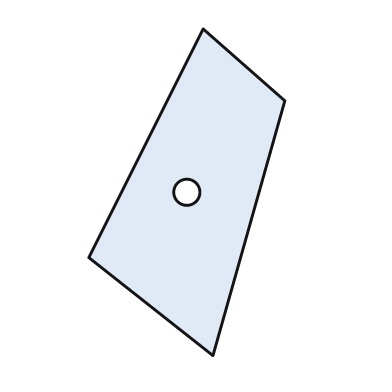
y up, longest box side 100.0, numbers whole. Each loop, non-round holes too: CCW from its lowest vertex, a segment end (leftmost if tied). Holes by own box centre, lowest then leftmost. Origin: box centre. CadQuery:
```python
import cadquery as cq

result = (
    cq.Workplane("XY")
    .moveTo(8.0, -50.0)
    .lineTo(30.0, 28.0)
    .lineTo(5.0, 50.0)
    .lineTo(-30.0, -20.0)
    .close()
    .moveTo(0.0, 0.0)
    .circle(4.0)
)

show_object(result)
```